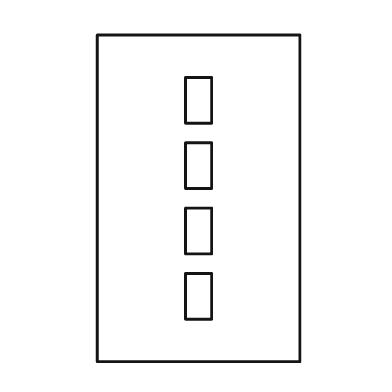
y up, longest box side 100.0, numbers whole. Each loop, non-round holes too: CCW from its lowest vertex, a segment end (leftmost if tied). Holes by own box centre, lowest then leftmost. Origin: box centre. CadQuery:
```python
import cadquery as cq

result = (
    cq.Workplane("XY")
    .moveTo(-31.0, -50.0)
    .lineTo(31.0, -50.0)
    .lineTo(31.0, 50.0)
    .lineTo(-31.0, 50.0)
    .close()
    .moveTo(-4.0, -37.0)
    .lineTo(4.0, -37.0)
    .lineTo(4.0, -23.0)
    .lineTo(-4.0, -23.0)
    .close()
    .moveTo(-4.0, -17.0)
    .lineTo(4.0, -17.0)
    .lineTo(4.0, -3.0)
    .lineTo(-4.0, -3.0)
    .close()
    .moveTo(-4.0, 3.0)
    .lineTo(4.0, 3.0)
    .lineTo(4.0, 17.0)
    .lineTo(-4.0, 17.0)
    .close()
    .moveTo(-4.0, 23.0)
    .lineTo(4.0, 23.0)
    .lineTo(4.0, 37.0)
    .lineTo(-4.0, 37.0)
    .close()
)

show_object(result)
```